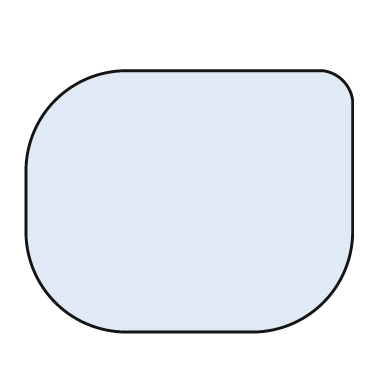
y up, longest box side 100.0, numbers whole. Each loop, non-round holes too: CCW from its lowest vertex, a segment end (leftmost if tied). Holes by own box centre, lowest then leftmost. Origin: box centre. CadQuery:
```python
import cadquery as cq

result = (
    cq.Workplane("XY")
    .moveTo(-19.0, -40.0)
    .lineTo(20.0, -40.0)
    .threePointArc((41.0, -31.0), (50.0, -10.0))
    .lineTo(50.0, 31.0)
    .threePointArc((47.0, 37.0), (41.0, 40.0))
    .lineTo(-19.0, 40.0)
    .threePointArc((-41.0, 31.0), (-50.0, 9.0))
    .lineTo(-50.0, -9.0)
    .threePointArc((-41.0, -31.0), (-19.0, -40.0))
    .close()
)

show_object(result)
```